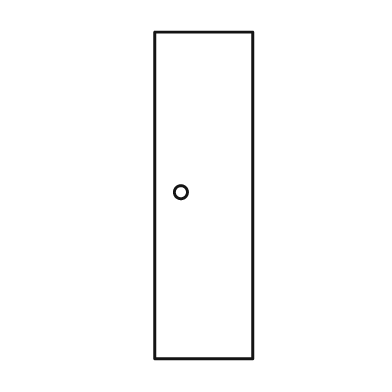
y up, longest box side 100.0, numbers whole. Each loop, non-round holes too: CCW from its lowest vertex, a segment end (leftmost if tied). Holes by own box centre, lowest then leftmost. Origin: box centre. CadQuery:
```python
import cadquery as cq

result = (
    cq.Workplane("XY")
    .moveTo(-15.0, -50.0)
    .lineTo(15.0, -50.0)
    .lineTo(15.0, 50.0)
    .lineTo(-15.0, 50.0)
    .close()
    .moveTo(-7.0, 1.0)
    .circle(2.0)
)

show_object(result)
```